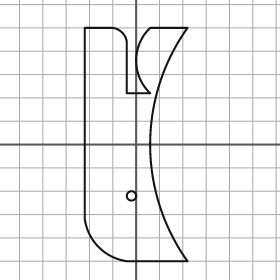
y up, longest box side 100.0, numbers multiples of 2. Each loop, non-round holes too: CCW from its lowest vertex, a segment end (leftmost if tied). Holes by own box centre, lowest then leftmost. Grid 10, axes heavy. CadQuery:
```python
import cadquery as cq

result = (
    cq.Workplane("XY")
    .moveTo(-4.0, -50.0)
    .lineTo(22.0, -50.0)
    .threePointArc((6.0, 0.0), (22.0, 50.0))
    .lineTo(6.0, 50.0)
    .threePointArc((0.0, 36.0), (6.0, 22.0))
    .lineTo(-4.0, 22.0)
    .lineTo(-4.0, 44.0)
    .threePointArc((-6.0, 48.0), (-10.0, 50.0))
    .lineTo(-22.0, 50.0)
    .lineTo(-22.0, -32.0)
    .threePointArc((-16.0, -44.0), (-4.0, -50.0))
    .close()
    .moveTo(-2.0, -22.0)
    .circle(2.0)
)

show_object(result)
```